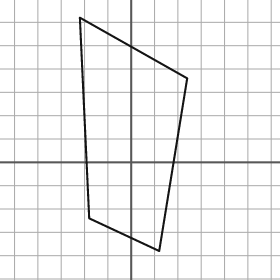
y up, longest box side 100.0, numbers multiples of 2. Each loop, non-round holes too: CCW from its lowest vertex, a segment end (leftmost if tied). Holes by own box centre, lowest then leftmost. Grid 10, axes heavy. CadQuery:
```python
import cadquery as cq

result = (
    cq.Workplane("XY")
    .moveTo(12.0, -38.0)
    .lineTo(24.0, 36.0)
    .lineTo(-22.0, 62.0)
    .lineTo(-18.0, -24.0)
    .close()
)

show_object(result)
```